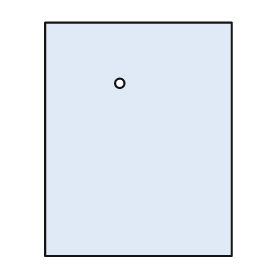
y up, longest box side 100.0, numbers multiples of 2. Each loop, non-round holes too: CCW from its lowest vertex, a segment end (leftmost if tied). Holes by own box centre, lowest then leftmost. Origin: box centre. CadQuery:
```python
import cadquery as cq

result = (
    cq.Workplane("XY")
    .moveTo(-40.0, -50.0)
    .lineTo(40.0, -50.0)
    .lineTo(40.0, 50.0)
    .lineTo(-40.0, 50.0)
    .close()
    .moveTo(-8.0, 24.0)
    .circle(2.0)
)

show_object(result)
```